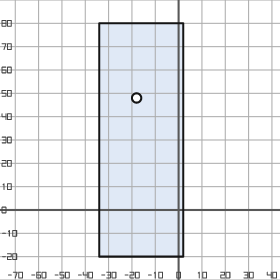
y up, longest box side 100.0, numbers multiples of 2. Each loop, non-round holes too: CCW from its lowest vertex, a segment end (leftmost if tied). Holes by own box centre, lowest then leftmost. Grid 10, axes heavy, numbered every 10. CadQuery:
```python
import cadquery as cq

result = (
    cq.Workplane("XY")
    .moveTo(-34.0, -20.0)
    .lineTo(2.0, -20.0)
    .lineTo(2.0, 80.0)
    .lineTo(-34.0, 80.0)
    .close()
    .moveTo(-18.0, 48.0)
    .circle(2.0)
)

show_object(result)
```